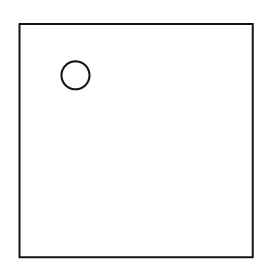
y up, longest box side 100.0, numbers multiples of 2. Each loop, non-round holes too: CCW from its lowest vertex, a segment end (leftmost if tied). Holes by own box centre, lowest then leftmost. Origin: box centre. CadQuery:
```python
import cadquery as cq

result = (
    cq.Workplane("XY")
    .moveTo(-50.0, -50.0)
    .lineTo(50.0, -50.0)
    .lineTo(50.0, 50.0)
    .lineTo(-50.0, 50.0)
    .close()
    .moveTo(-26.0, 28.0)
    .circle(6.0)
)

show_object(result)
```